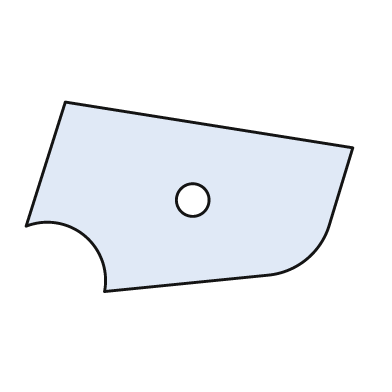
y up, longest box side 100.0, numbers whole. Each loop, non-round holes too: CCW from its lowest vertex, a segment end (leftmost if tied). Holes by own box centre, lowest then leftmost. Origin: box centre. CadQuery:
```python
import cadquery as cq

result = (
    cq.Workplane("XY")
    .moveTo(-26.0, -29.0)
    .lineTo(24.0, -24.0)
    .threePointArc((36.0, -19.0), (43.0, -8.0))
    .lineTo(50.0, 15.0)
    .lineTo(-38.0, 29.0)
    .lineTo(-50.0, -9.0)
    .threePointArc((-32.0, -12.0), (-26.0, -29.0))
    .close()
    .moveTo(1.0, -1.0)
    .circle(5.0)
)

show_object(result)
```